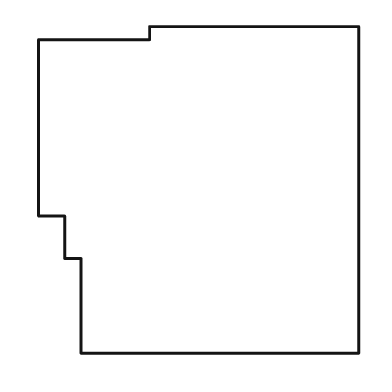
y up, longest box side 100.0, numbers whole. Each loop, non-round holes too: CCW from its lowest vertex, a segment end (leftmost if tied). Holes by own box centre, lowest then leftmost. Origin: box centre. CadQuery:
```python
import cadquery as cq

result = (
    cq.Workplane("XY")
    .moveTo(-36.0, -50.0)
    .lineTo(49.0, -50.0)
    .lineTo(49.0, 50.0)
    .lineTo(-15.0, 50.0)
    .lineTo(-15.0, 46.0)
    .lineTo(-49.0, 46.0)
    .lineTo(-49.0, -8.0)
    .lineTo(-41.0, -8.0)
    .lineTo(-41.0, -21.0)
    .lineTo(-36.0, -21.0)
    .close()
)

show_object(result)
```